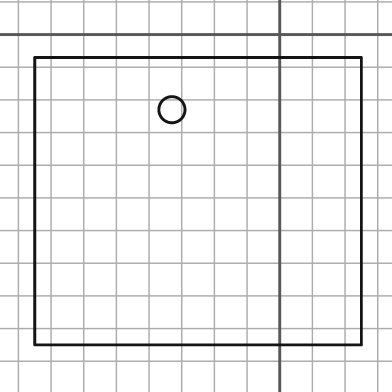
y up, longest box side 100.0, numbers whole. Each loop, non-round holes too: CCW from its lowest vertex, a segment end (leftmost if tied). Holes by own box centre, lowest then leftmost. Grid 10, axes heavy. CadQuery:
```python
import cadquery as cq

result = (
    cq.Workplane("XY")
    .moveTo(-75.0, -95.0)
    .lineTo(25.0, -95.0)
    .lineTo(25.0, -7.0)
    .lineTo(-75.0, -7.0)
    .close()
    .moveTo(-33.0, -23.0)
    .circle(4.0)
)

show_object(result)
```